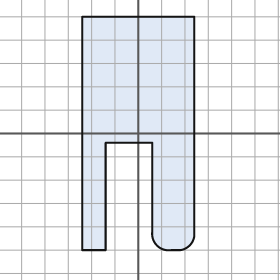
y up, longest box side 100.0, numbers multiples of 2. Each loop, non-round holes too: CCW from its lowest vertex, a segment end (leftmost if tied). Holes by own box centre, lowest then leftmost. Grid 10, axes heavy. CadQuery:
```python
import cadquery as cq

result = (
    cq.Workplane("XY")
    .moveTo(-24.0, -50.0)
    .lineTo(-14.0, -50.0)
    .lineTo(-14.0, -4.0)
    .lineTo(6.0, -4.0)
    .lineTo(6.0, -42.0)
    .threePointArc((8.0, -48.0), (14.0, -50.0))
    .lineTo(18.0, -50.0)
    .threePointArc((22.0, -48.0), (24.0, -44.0))
    .lineTo(24.0, 50.0)
    .lineTo(-24.0, 50.0)
    .close()
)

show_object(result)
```